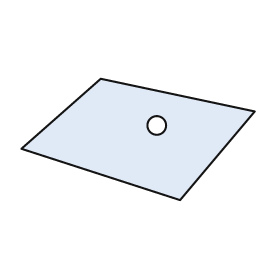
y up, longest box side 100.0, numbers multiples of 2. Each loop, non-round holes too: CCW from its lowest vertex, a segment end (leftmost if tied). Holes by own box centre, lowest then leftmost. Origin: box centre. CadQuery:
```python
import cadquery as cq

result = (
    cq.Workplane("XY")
    .moveTo(18.0, -26.0)
    .lineTo(50.0, 12.0)
    .lineTo(-16.0, 26.0)
    .lineTo(-50.0, -4.0)
    .close()
    .moveTo(8.0, 6.0)
    .circle(4.0)
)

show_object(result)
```